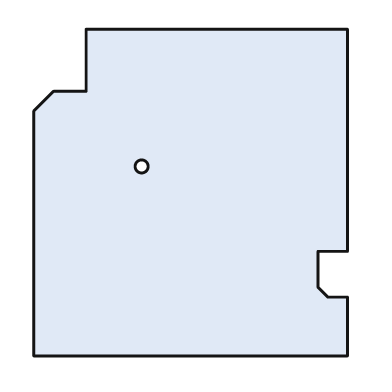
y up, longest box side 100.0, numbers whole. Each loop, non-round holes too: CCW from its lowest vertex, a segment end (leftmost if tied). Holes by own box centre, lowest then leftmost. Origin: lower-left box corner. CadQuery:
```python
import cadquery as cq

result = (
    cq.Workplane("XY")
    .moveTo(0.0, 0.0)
    .lineTo(96.0, 0.0)
    .lineTo(96.0, 18.0)
    .lineTo(90.0, 18.0)
    .lineTo(87.0, 21.0)
    .lineTo(87.0, 32.0)
    .lineTo(96.0, 32.0)
    .lineTo(96.0, 100.0)
    .lineTo(16.0, 100.0)
    .lineTo(16.0, 81.0)
    .lineTo(6.0, 81.0)
    .lineTo(0.0, 75.0)
    .close()
    .moveTo(33.0, 58.0)
    .circle(2.0)
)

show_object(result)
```